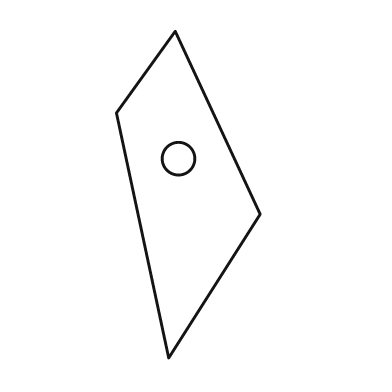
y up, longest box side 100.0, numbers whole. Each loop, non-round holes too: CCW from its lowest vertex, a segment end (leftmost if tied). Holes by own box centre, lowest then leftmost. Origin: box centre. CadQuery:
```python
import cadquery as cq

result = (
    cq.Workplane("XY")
    .moveTo(-6.0, -50.0)
    .lineTo(22.0, -6.0)
    .lineTo(-4.0, 50.0)
    .lineTo(-22.0, 25.0)
    .close()
    .moveTo(-3.0, 11.0)
    .circle(5.0)
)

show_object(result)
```